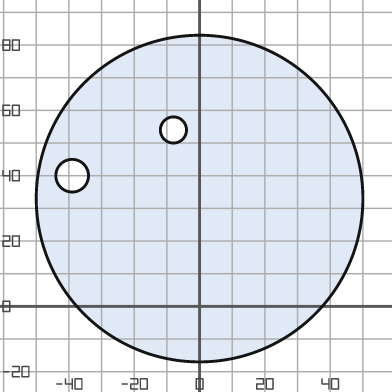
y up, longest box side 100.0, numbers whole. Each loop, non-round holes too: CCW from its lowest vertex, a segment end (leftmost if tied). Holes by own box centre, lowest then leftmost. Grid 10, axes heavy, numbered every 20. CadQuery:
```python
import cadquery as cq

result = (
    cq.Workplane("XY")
    .moveTo(0.0, 33.0)
    .circle(50.0)
    .moveTo(-39.0, 40.0)
    .circle(5.0)
    .moveTo(-8.0, 54.0)
    .circle(4.0)
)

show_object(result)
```